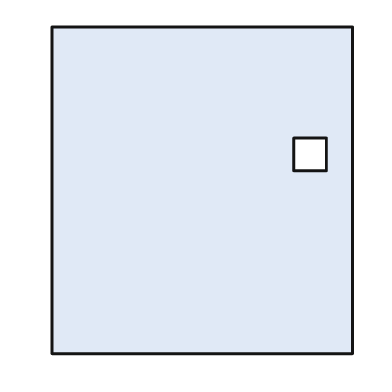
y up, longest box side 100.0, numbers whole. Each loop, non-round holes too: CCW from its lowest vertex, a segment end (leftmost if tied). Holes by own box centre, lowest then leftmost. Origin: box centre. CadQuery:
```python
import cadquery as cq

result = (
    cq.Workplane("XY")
    .moveTo(-46.0, -50.0)
    .lineTo(46.0, -50.0)
    .lineTo(46.0, 50.0)
    .lineTo(-46.0, 50.0)
    .close()
    .moveTo(28.0, 6.0)
    .lineTo(38.0, 6.0)
    .lineTo(38.0, 16.0)
    .lineTo(28.0, 16.0)
    .close()
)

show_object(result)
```